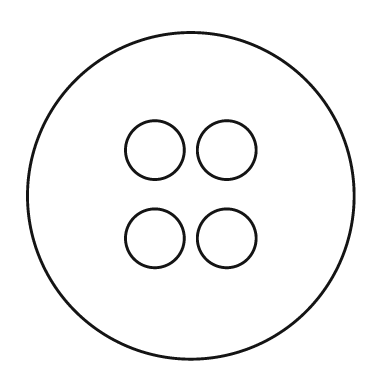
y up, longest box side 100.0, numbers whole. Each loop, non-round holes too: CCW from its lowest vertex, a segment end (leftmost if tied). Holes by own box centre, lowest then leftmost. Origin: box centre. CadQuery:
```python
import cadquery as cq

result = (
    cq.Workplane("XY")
    .moveTo(0.0, 0.0)
    .circle(50.0)
    .moveTo(-11.0, -13.0)
    .circle(9.0)
    .moveTo(11.0, -13.0)
    .circle(9.0)
    .moveTo(-11.0, 14.0)
    .circle(9.0)
    .moveTo(11.0, 14.0)
    .circle(9.0)
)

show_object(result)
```